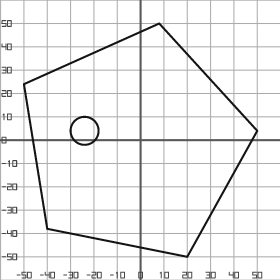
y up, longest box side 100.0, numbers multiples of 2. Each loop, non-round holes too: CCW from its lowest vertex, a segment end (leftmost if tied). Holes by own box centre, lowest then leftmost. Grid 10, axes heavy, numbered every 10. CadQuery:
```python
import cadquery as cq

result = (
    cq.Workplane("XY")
    .moveTo(20.0, -50.0)
    .lineTo(50.0, 4.0)
    .lineTo(8.0, 50.0)
    .lineTo(-50.0, 24.0)
    .lineTo(-40.0, -38.0)
    .close()
    .moveTo(-24.0, 4.0)
    .circle(6.0)
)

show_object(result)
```